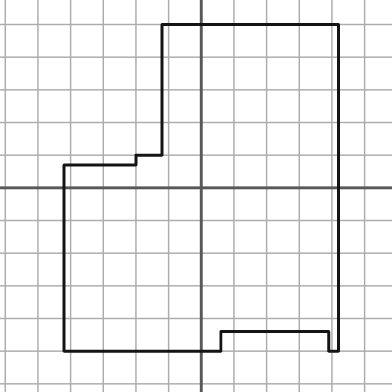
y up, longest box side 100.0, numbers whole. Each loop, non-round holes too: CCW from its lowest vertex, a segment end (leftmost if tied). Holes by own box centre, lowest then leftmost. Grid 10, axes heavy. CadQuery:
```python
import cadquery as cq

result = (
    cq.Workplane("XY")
    .moveTo(-42.0, -50.0)
    .lineTo(6.0, -50.0)
    .lineTo(6.0, -44.0)
    .lineTo(39.0, -44.0)
    .lineTo(39.0, -50.0)
    .lineTo(42.0, -50.0)
    .lineTo(42.0, 50.0)
    .lineTo(-12.0, 50.0)
    .lineTo(-12.0, 10.0)
    .lineTo(-20.0, 10.0)
    .lineTo(-20.0, 7.0)
    .lineTo(-42.0, 7.0)
    .close()
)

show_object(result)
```